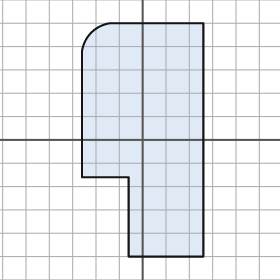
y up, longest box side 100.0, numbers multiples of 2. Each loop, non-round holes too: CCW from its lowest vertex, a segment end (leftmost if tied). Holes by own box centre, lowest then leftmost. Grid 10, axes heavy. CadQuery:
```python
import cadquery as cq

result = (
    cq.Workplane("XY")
    .moveTo(-6.0, -50.0)
    .lineTo(26.0, -50.0)
    .lineTo(26.0, 50.0)
    .lineTo(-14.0, 50.0)
    .threePointArc((-22.0, 46.0), (-26.0, 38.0))
    .lineTo(-26.0, -16.0)
    .lineTo(-6.0, -16.0)
    .close()
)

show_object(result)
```